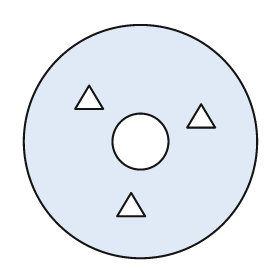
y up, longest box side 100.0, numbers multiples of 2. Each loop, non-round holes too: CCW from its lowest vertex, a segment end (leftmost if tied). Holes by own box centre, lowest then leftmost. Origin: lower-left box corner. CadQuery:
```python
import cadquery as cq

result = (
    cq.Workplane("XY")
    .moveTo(50.0, 50.0)
    .circle(50.0)
    .moveTo(40.0, 18.0)
    .lineTo(52.0, 18.0)
    .lineTo(46.0, 28.0)
    .close()
    .moveTo(50.0, 50.0)
    .circle(12.0)
    .moveTo(70.0, 56.0)
    .lineTo(82.0, 56.0)
    .lineTo(76.0, 66.0)
    .close()
    .moveTo(22.0, 64.0)
    .lineTo(34.0, 64.0)
    .lineTo(28.0, 74.0)
    .close()
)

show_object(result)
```